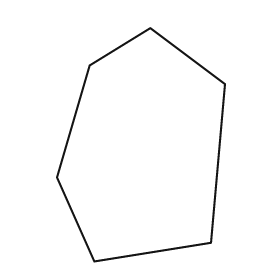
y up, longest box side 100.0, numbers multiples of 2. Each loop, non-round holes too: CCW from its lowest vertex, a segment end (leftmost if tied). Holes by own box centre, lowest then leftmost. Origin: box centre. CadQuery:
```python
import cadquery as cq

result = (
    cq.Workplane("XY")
    .moveTo(-20.0, -50.0)
    .lineTo(30.0, -42.0)
    .lineTo(36.0, 26.0)
    .lineTo(4.0, 50.0)
    .lineTo(-22.0, 34.0)
    .lineTo(-36.0, -14.0)
    .close()
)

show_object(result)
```